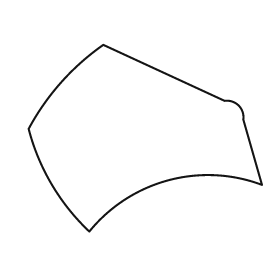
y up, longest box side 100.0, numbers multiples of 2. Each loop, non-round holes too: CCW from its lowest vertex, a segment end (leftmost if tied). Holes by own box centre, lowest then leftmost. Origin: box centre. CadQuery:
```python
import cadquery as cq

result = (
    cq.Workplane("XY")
    .moveTo(-24.0, -40.0)
    .threePointArc((10.0, -18.0), (50.0, -20.0))
    .lineTo(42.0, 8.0)
    .threePointArc((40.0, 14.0), (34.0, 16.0))
    .lineTo(-18.0, 40.0)
    .threePointArc((-36.0, 24.0), (-50.0, 4.0))
    .threePointArc((-40.0, -20.0), (-24.0, -40.0))
    .close()
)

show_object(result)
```